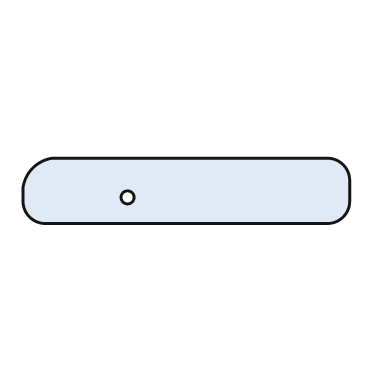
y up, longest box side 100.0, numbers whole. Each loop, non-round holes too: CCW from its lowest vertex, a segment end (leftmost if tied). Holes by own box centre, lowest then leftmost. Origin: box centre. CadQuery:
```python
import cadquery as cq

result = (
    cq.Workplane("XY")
    .moveTo(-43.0, -10.0)
    .lineTo(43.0, -10.0)
    .threePointArc((48.0, -8.0), (50.0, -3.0))
    .lineTo(50.0, 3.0)
    .threePointArc((48.0, 8.0), (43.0, 10.0))
    .lineTo(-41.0, 10.0)
    .threePointArc((-47.0, 7.0), (-50.0, 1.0))
    .lineTo(-50.0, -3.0)
    .threePointArc((-48.0, -8.0), (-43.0, -10.0))
    .close()
    .moveTo(-18.0, -2.0)
    .circle(2.0)
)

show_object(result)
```